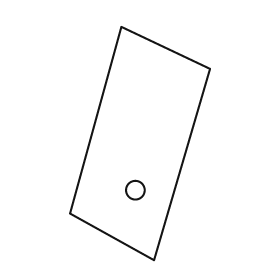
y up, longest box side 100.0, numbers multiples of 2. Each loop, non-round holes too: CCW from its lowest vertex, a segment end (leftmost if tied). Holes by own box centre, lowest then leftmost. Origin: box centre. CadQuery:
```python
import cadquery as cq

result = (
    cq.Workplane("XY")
    .moveTo(6.0, -50.0)
    .lineTo(30.0, 32.0)
    .lineTo(-8.0, 50.0)
    .lineTo(-30.0, -30.0)
    .close()
    .moveTo(-2.0, -20.0)
    .circle(4.0)
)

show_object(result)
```